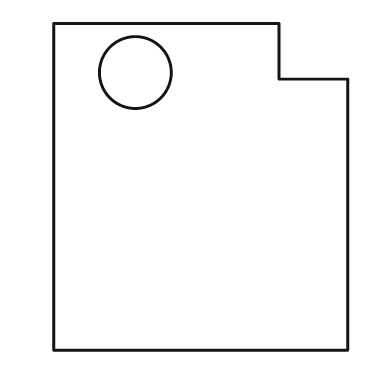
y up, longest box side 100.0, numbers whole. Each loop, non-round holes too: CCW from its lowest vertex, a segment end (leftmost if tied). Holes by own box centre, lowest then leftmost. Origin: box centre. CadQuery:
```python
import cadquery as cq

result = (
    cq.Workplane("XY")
    .moveTo(-45.0, -50.0)
    .lineTo(45.0, -50.0)
    .lineTo(45.0, 33.0)
    .lineTo(24.0, 33.0)
    .lineTo(24.0, 50.0)
    .lineTo(-45.0, 50.0)
    .close()
    .moveTo(-20.0, 35.0)
    .circle(11.0)
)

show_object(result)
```